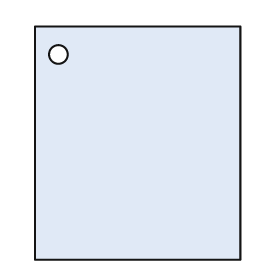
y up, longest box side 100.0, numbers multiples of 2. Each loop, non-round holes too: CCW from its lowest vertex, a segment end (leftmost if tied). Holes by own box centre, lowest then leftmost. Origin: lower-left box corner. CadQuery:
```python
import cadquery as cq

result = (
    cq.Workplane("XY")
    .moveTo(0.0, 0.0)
    .lineTo(88.0, 0.0)
    .lineTo(88.0, 100.0)
    .lineTo(0.0, 100.0)
    .close()
    .moveTo(10.0, 88.0)
    .circle(4.0)
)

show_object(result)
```